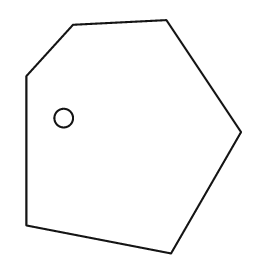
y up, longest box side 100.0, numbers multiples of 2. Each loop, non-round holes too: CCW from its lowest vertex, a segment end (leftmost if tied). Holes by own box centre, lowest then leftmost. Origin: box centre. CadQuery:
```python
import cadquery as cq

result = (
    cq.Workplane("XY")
    .moveTo(16.0, -50.0)
    .lineTo(46.0, 2.0)
    .lineTo(14.0, 50.0)
    .lineTo(-26.0, 48.0)
    .lineTo(-46.0, 26.0)
    .lineTo(-46.0, -38.0)
    .close()
    .moveTo(-30.0, 8.0)
    .circle(4.0)
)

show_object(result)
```